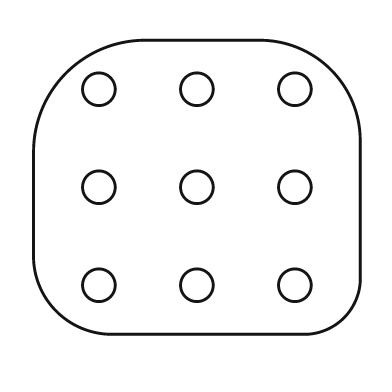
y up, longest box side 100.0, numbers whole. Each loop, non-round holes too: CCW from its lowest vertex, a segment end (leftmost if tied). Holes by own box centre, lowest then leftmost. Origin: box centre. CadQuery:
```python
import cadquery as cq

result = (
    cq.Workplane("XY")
    .moveTo(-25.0, -45.0)
    .lineTo(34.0, -45.0)
    .threePointArc((45.0, -40.0), (50.0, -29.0))
    .lineTo(50.0, 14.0)
    .threePointArc((41.0, 36.0), (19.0, 45.0))
    .lineTo(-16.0, 45.0)
    .threePointArc((-40.0, 35.0), (-50.0, 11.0))
    .lineTo(-50.0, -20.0)
    .threePointArc((-43.0, -38.0), (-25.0, -45.0))
    .close()
    .moveTo(-30.0, -30.0)
    .circle(5.0)
    .moveTo(0.0, -30.0)
    .circle(5.0)
    .moveTo(30.0, -30.0)
    .circle(5.0)
    .moveTo(-30.0, 0.0)
    .circle(5.0)
    .moveTo(0.0, 0.0)
    .circle(5.0)
    .moveTo(30.0, 0.0)
    .circle(5.0)
    .moveTo(-30.0, 30.0)
    .circle(5.0)
    .moveTo(0.0, 30.0)
    .circle(5.0)
    .moveTo(30.0, 30.0)
    .circle(5.0)
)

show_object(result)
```